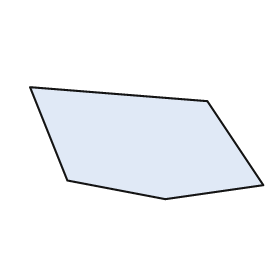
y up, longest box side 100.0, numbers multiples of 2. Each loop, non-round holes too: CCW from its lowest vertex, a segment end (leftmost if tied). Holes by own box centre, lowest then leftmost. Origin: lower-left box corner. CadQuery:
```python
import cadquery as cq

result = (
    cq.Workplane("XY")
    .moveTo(58.0, 0.0)
    .lineTo(100.0, 6.0)
    .lineTo(76.0, 42.0)
    .lineTo(0.0, 48.0)
    .lineTo(16.0, 8.0)
    .close()
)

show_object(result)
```